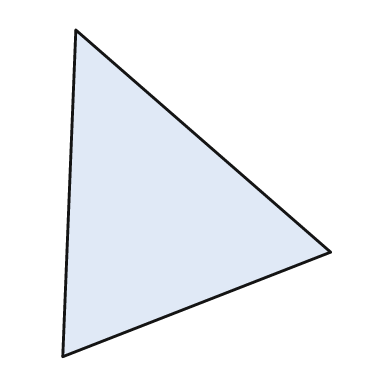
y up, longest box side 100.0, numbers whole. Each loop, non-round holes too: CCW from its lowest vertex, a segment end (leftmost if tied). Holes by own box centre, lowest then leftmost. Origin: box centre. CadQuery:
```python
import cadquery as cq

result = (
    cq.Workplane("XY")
    .moveTo(-41.0, -50.0)
    .lineTo(41.0, -18.0)
    .lineTo(-37.0, 50.0)
    .close()
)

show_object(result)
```